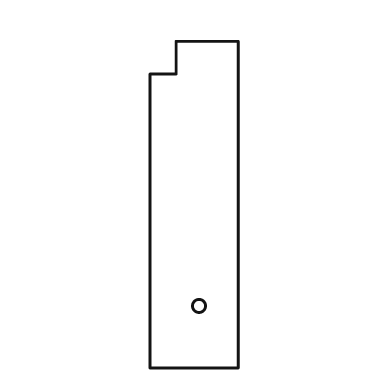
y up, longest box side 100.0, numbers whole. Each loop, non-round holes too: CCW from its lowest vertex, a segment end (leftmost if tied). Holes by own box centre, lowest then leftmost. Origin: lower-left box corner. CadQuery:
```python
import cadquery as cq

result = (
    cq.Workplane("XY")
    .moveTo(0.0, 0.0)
    .lineTo(27.0, 0.0)
    .lineTo(27.0, 100.0)
    .lineTo(8.0, 100.0)
    .lineTo(8.0, 90.0)
    .lineTo(0.0, 90.0)
    .close()
    .moveTo(15.0, 19.0)
    .circle(2.0)
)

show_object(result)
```